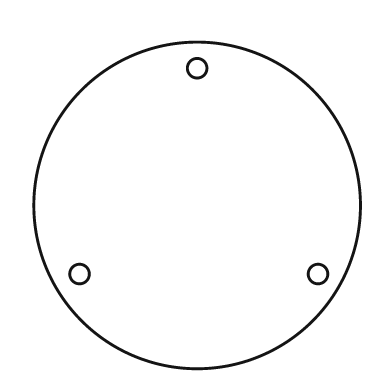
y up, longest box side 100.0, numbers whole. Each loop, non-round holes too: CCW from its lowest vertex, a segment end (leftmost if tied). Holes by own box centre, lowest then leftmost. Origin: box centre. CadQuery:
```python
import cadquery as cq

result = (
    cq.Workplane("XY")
    .moveTo(0.0, 0.0)
    .circle(50.0)
    .moveTo(-36.0, -21.0)
    .circle(3.0)
    .moveTo(37.0, -21.0)
    .circle(3.0)
    .moveTo(0.0, 42.0)
    .circle(3.0)
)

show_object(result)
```